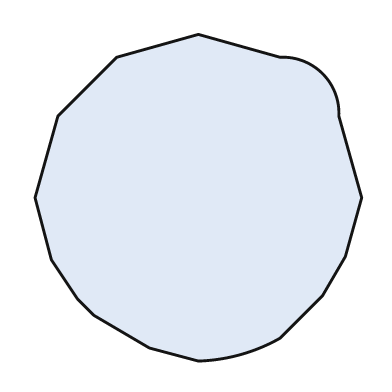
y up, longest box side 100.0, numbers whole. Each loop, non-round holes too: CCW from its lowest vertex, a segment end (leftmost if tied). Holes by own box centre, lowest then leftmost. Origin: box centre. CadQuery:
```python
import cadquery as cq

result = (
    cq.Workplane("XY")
    .moveTo(0.0, -50.0)
    .threePointArc((13.0, -48.0), (25.0, -43.0))
    .lineTo(38.0, -30.0)
    .lineTo(45.0, -18.0)
    .lineTo(50.0, 0.0)
    .lineTo(43.0, 25.0)
    .threePointArc((38.0, 38.0), (25.0, 43.0))
    .lineTo(0.0, 50.0)
    .lineTo(-25.0, 43.0)
    .lineTo(-43.0, 25.0)
    .lineTo(-50.0, 0.0)
    .lineTo(-45.0, -19.0)
    .lineTo(-37.0, -31.0)
    .lineTo(-32.0, -36.0)
    .lineTo(-15.0, -46.0)
    .close()
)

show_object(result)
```